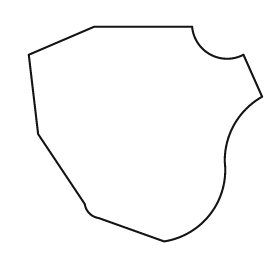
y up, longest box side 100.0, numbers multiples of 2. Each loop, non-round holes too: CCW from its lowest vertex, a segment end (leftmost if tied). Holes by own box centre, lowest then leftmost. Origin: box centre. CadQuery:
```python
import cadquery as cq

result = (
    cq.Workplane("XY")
    .moveTo(8.0, -46.0)
    .threePointArc((28.0, -34.0), (34.0, -12.0))
    .threePointArc((38.0, 4.0), (50.0, 16.0))
    .lineTo(42.0, 34.0)
    .threePointArc((28.0, 34.0), (20.0, 46.0))
    .lineTo(-22.0, 46.0)
    .lineTo(-50.0, 34.0)
    .lineTo(-46.0, 0.0)
    .lineTo(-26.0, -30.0)
    .threePointArc((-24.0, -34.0), (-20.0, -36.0))
    .close()
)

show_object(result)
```